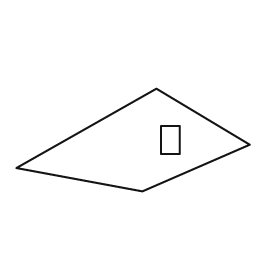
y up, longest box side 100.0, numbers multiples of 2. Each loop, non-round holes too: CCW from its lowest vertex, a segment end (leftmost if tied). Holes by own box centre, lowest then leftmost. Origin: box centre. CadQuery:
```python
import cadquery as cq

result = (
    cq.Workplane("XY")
    .moveTo(4.0, -22.0)
    .lineTo(50.0, -2.0)
    .lineTo(10.0, 22.0)
    .lineTo(-50.0, -12.0)
    .close()
    .moveTo(12.0, -6.0)
    .lineTo(20.0, -6.0)
    .lineTo(20.0, 6.0)
    .lineTo(12.0, 6.0)
    .close()
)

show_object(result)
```